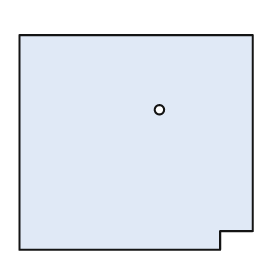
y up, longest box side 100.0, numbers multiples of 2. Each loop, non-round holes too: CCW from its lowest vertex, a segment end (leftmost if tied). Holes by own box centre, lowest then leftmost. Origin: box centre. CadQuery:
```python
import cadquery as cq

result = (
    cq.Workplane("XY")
    .moveTo(-50.0, -46.0)
    .lineTo(36.0, -46.0)
    .lineTo(36.0, -38.0)
    .lineTo(50.0, -38.0)
    .lineTo(50.0, 46.0)
    .lineTo(-50.0, 46.0)
    .close()
    .moveTo(10.0, 14.0)
    .circle(2.0)
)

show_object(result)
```